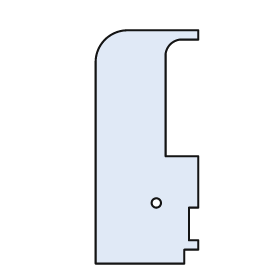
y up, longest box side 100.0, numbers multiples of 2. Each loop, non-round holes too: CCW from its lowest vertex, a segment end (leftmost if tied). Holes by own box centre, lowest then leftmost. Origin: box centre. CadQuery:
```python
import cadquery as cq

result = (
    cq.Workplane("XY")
    .moveTo(-22.0, -50.0)
    .lineTo(16.0, -50.0)
    .lineTo(16.0, -44.0)
    .lineTo(22.0, -44.0)
    .lineTo(22.0, -40.0)
    .lineTo(18.0, -40.0)
    .lineTo(18.0, -26.0)
    .lineTo(22.0, -26.0)
    .lineTo(22.0, -4.0)
    .lineTo(8.0, -4.0)
    .lineTo(8.0, 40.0)
    .threePointArc((10.0, 44.0), (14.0, 46.0))
    .lineTo(22.0, 46.0)
    .lineTo(22.0, 50.0)
    .lineTo(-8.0, 50.0)
    .threePointArc((-18.0, 46.0), (-22.0, 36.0))
    .close()
    .moveTo(4.0, -24.0)
    .circle(2.0)
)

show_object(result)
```